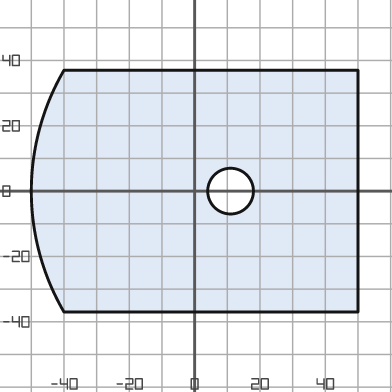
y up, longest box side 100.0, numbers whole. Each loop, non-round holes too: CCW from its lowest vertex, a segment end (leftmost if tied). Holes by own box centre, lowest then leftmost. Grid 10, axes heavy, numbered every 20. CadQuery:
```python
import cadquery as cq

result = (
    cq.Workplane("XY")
    .moveTo(-40.0, -37.0)
    .lineTo(50.0, -37.0)
    .lineTo(50.0, 37.0)
    .lineTo(-40.0, 37.0)
    .threePointArc((-50.0, 0.0), (-40.0, -37.0))
    .close()
    .moveTo(11.0, 0.0)
    .circle(7.0)
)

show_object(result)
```